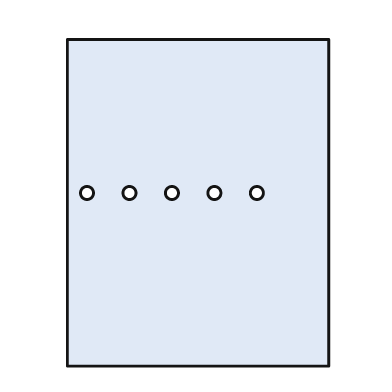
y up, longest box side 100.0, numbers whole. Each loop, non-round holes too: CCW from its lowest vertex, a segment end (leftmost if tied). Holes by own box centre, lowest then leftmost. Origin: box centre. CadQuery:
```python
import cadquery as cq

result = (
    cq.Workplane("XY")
    .moveTo(-40.0, -50.0)
    .lineTo(40.0, -50.0)
    .lineTo(40.0, 50.0)
    .lineTo(-40.0, 50.0)
    .close()
    .moveTo(-34.0, 3.0)
    .circle(2.0)
    .moveTo(-21.0, 3.0)
    .circle(2.0)
    .moveTo(-8.0, 3.0)
    .circle(2.0)
    .moveTo(5.0, 3.0)
    .circle(2.0)
    .moveTo(18.0, 3.0)
    .circle(2.0)
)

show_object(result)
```